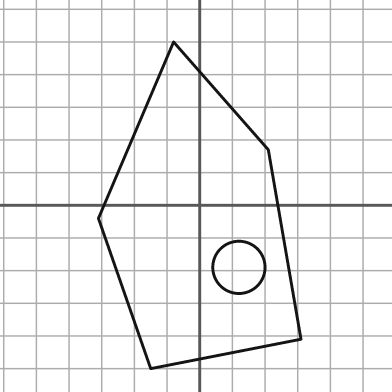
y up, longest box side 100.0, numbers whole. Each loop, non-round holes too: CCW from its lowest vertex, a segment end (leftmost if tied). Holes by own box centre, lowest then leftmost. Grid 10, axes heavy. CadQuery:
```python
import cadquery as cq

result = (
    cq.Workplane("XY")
    .moveTo(-15.0, -50.0)
    .lineTo(31.0, -41.0)
    .lineTo(21.0, 17.0)
    .lineTo(-8.0, 50.0)
    .lineTo(-31.0, -4.0)
    .close()
    .moveTo(12.0, -19.0)
    .circle(8.0)
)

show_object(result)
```